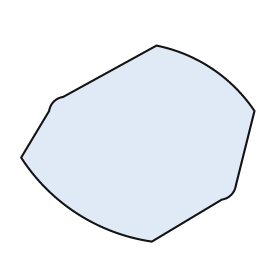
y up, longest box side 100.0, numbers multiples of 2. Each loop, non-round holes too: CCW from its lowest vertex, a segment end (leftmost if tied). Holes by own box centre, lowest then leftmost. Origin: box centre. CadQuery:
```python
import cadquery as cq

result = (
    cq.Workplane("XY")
    .moveTo(6.0, -42.0)
    .lineTo(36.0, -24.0)
    .threePointArc((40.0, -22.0), (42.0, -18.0))
    .lineTo(50.0, 14.0)
    .threePointArc((32.0, 32.0), (8.0, 42.0))
    .lineTo(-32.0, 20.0)
    .threePointArc((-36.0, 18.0), (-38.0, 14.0))
    .lineTo(-50.0, -6.0)
    .threePointArc((-26.0, -30.0), (6.0, -42.0))
    .close()
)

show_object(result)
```